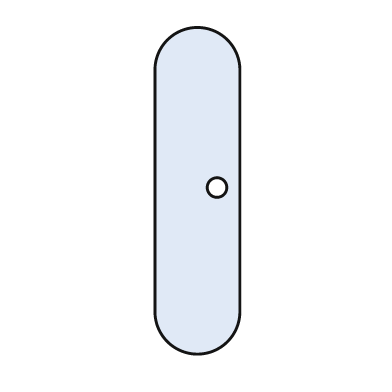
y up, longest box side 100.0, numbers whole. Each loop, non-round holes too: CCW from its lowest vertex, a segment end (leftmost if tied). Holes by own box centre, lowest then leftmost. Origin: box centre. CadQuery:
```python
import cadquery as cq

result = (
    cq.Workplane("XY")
    .moveTo(-13.0, -37.0)
    .threePointArc((0.0, -50.0), (13.0, -37.0))
    .lineTo(13.0, 37.0)
    .threePointArc((0.0, 50.0), (-13.0, 37.0))
    .close()
    .moveTo(6.0, 1.0)
    .circle(3.0)
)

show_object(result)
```